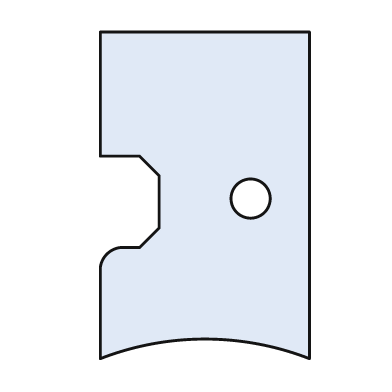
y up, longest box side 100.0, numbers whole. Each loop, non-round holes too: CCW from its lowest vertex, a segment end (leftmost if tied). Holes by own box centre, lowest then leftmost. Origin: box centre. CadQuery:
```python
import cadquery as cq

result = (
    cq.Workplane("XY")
    .moveTo(-32.0, -50.0)
    .threePointArc((0.0, -44.0), (32.0, -50.0))
    .lineTo(32.0, 50.0)
    .lineTo(-32.0, 50.0)
    .lineTo(-32.0, 12.0)
    .lineTo(-20.0, 12.0)
    .lineTo(-14.0, 6.0)
    .lineTo(-14.0, -10.0)
    .lineTo(-20.0, -16.0)
    .lineTo(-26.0, -16.0)
    .threePointArc((-30.0, -18.0), (-32.0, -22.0))
    .close()
    .moveTo(14.0, -1.0)
    .circle(6.0)
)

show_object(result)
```